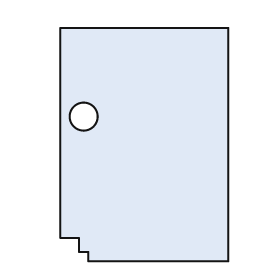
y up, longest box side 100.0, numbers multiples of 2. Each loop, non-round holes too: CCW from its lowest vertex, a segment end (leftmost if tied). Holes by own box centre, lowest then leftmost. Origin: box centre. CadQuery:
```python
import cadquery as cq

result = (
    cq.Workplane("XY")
    .moveTo(-24.0, -50.0)
    .lineTo(36.0, -50.0)
    .lineTo(36.0, 50.0)
    .lineTo(-36.0, 50.0)
    .lineTo(-36.0, -40.0)
    .lineTo(-28.0, -40.0)
    .lineTo(-28.0, -46.0)
    .lineTo(-24.0, -46.0)
    .close()
    .moveTo(-26.0, 12.0)
    .circle(6.0)
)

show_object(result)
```